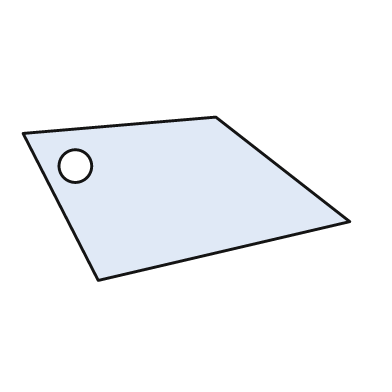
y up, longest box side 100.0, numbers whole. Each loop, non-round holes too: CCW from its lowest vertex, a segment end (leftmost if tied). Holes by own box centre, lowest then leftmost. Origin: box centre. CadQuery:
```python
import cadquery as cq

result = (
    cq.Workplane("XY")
    .moveTo(-27.0, -25.0)
    .lineTo(50.0, -7.0)
    .lineTo(9.0, 25.0)
    .lineTo(-50.0, 20.0)
    .close()
    .moveTo(-34.0, 10.0)
    .circle(5.0)
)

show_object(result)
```